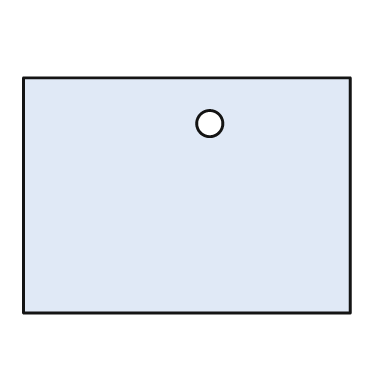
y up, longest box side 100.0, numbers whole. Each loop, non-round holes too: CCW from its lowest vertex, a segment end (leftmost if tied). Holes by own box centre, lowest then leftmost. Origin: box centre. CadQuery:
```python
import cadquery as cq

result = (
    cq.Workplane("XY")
    .moveTo(-50.0, -36.0)
    .lineTo(50.0, -36.0)
    .lineTo(50.0, 36.0)
    .lineTo(-50.0, 36.0)
    .close()
    .moveTo(7.0, 22.0)
    .circle(4.0)
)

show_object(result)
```